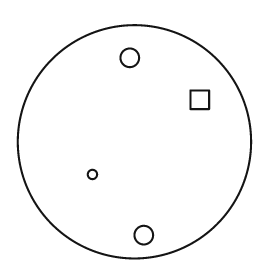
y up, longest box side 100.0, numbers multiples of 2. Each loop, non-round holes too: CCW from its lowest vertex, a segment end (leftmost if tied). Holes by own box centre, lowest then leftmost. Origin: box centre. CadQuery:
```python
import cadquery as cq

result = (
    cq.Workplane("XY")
    .moveTo(0.0, 0.0)
    .circle(50.0)
    .moveTo(4.0, -40.0)
    .circle(4.0)
    .moveTo(-18.0, -14.0)
    .circle(2.0)
    .moveTo(24.0, 14.0)
    .lineTo(32.0, 14.0)
    .lineTo(32.0, 22.0)
    .lineTo(24.0, 22.0)
    .close()
    .moveTo(-2.0, 36.0)
    .circle(4.0)
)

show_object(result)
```